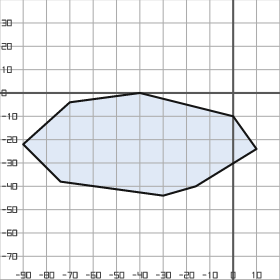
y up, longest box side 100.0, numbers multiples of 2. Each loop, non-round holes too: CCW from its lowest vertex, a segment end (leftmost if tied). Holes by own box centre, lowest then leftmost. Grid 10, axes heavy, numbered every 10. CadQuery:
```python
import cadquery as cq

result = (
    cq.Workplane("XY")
    .moveTo(-30.0, -44.0)
    .lineTo(-16.0, -40.0)
    .lineTo(10.0, -24.0)
    .lineTo(0.0, -10.0)
    .lineTo(-40.0, 0.0)
    .lineTo(-70.0, -4.0)
    .lineTo(-90.0, -22.0)
    .lineTo(-74.0, -38.0)
    .close()
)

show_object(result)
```